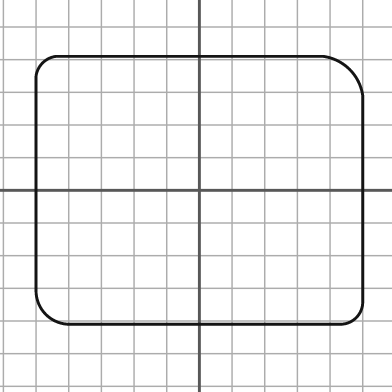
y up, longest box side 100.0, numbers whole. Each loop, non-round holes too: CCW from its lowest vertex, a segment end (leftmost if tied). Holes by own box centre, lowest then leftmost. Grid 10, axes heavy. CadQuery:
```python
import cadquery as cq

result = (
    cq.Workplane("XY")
    .moveTo(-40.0, -41.0)
    .lineTo(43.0, -41.0)
    .threePointArc((48.0, -39.0), (50.0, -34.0))
    .lineTo(50.0, 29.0)
    .threePointArc((46.0, 37.0), (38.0, 41.0))
    .lineTo(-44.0, 41.0)
    .threePointArc((-48.0, 39.0), (-50.0, 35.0))
    .lineTo(-50.0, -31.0)
    .threePointArc((-47.0, -38.0), (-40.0, -41.0))
    .close()
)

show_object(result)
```